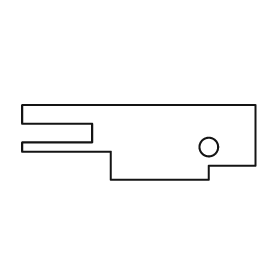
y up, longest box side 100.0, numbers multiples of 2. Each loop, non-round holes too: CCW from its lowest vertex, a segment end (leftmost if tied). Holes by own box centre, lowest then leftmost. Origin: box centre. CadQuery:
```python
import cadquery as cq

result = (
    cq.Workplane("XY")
    .moveTo(-12.0, -16.0)
    .lineTo(30.0, -16.0)
    .lineTo(30.0, -10.0)
    .lineTo(50.0, -10.0)
    .lineTo(50.0, 16.0)
    .lineTo(-50.0, 16.0)
    .lineTo(-50.0, 8.0)
    .lineTo(-20.0, 8.0)
    .lineTo(-20.0, 0.0)
    .lineTo(-50.0, 0.0)
    .lineTo(-50.0, -4.0)
    .lineTo(-12.0, -4.0)
    .close()
    .moveTo(30.0, -2.0)
    .circle(4.0)
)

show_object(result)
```